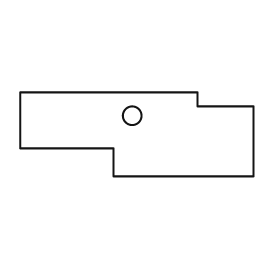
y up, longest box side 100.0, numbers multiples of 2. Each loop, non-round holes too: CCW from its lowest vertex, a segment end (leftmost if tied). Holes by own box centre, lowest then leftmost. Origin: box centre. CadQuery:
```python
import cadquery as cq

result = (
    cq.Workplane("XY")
    .moveTo(-10.0, -18.0)
    .lineTo(50.0, -18.0)
    .lineTo(50.0, 12.0)
    .lineTo(26.0, 12.0)
    .lineTo(26.0, 18.0)
    .lineTo(-50.0, 18.0)
    .lineTo(-50.0, -6.0)
    .lineTo(-10.0, -6.0)
    .close()
    .moveTo(-2.0, 8.0)
    .circle(4.0)
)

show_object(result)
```